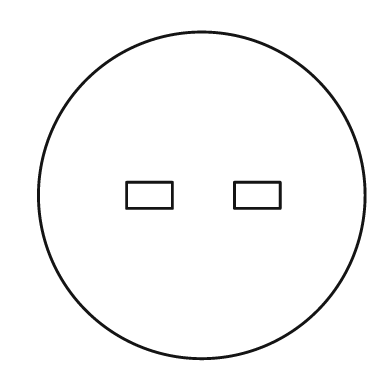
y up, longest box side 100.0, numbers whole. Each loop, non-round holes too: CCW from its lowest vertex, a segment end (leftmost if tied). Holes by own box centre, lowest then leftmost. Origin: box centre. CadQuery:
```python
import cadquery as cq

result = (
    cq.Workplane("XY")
    .moveTo(0.0, 0.0)
    .circle(50.0)
    .moveTo(-23.0, -4.0)
    .lineTo(-9.0, -4.0)
    .lineTo(-9.0, 4.0)
    .lineTo(-23.0, 4.0)
    .close()
    .moveTo(10.0, -4.0)
    .lineTo(24.0, -4.0)
    .lineTo(24.0, 4.0)
    .lineTo(10.0, 4.0)
    .close()
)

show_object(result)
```